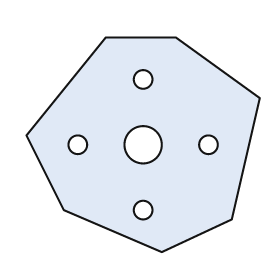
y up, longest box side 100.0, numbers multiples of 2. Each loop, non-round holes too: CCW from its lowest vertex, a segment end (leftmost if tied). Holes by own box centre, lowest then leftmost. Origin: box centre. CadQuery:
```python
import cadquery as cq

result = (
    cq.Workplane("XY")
    .moveTo(8.0, -46.0)
    .lineTo(38.0, -32.0)
    .lineTo(50.0, 20.0)
    .lineTo(14.0, 46.0)
    .lineTo(-16.0, 46.0)
    .lineTo(-50.0, 4.0)
    .lineTo(-34.0, -28.0)
    .close()
    .moveTo(0.0, -28.0)
    .circle(4.0)
    .moveTo(-28.0, 0.0)
    .circle(4.0)
    .moveTo(0.0, 0.0)
    .circle(8.0)
    .moveTo(28.0, 0.0)
    .circle(4.0)
    .moveTo(0.0, 28.0)
    .circle(4.0)
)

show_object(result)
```